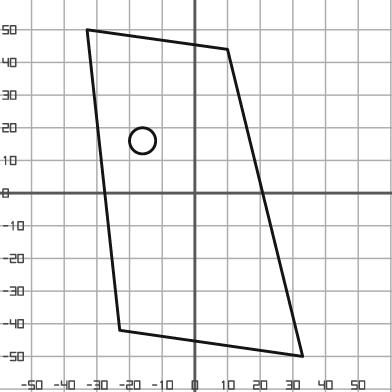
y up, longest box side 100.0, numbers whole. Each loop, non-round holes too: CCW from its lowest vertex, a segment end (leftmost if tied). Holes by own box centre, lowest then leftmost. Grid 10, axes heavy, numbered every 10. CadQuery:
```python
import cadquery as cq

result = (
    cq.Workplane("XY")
    .moveTo(33.0, -50.0)
    .lineTo(10.0, 44.0)
    .lineTo(-33.0, 50.0)
    .lineTo(-23.0, -42.0)
    .close()
    .moveTo(-16.0, 16.0)
    .circle(4.0)
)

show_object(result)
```